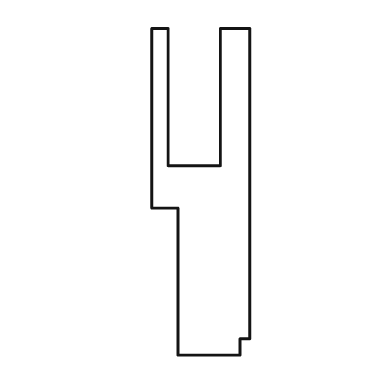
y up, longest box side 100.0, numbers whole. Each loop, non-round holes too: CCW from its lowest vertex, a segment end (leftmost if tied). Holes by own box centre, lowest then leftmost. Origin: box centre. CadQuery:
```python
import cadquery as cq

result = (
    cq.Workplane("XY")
    .moveTo(-7.0, -50.0)
    .lineTo(12.0, -50.0)
    .lineTo(12.0, -45.0)
    .lineTo(15.0, -45.0)
    .lineTo(15.0, 50.0)
    .lineTo(6.0, 50.0)
    .lineTo(6.0, 8.0)
    .lineTo(-10.0, 8.0)
    .lineTo(-10.0, 50.0)
    .lineTo(-15.0, 50.0)
    .lineTo(-15.0, -5.0)
    .lineTo(-7.0, -5.0)
    .close()
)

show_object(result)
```